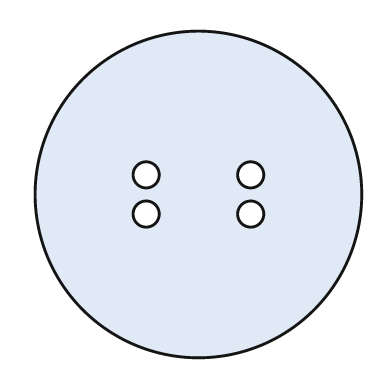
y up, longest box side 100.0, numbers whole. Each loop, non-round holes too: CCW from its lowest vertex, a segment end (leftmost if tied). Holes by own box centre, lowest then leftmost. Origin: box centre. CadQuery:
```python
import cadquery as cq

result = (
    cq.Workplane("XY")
    .moveTo(0.0, 0.0)
    .circle(50.0)
    .moveTo(-16.0, -6.0)
    .circle(4.0)
    .moveTo(16.0, -6.0)
    .circle(4.0)
    .moveTo(-16.0, 6.0)
    .circle(4.0)
    .moveTo(16.0, 6.0)
    .circle(4.0)
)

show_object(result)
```